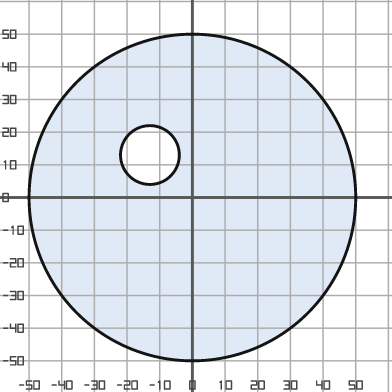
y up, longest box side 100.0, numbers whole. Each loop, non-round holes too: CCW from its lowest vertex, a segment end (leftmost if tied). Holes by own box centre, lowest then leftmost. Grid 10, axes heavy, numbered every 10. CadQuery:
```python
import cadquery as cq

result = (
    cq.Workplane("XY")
    .moveTo(0.0, 0.0)
    .circle(50.0)
    .moveTo(-13.0, 13.0)
    .circle(9.0)
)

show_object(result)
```